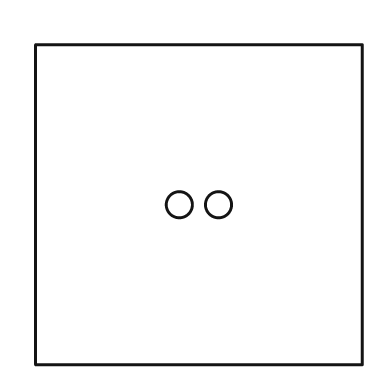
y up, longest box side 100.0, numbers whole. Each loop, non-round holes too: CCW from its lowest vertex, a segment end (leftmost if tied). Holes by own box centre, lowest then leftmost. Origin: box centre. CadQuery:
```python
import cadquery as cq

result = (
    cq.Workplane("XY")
    .moveTo(-50.0, -49.0)
    .lineTo(50.0, -49.0)
    .lineTo(50.0, 49.0)
    .lineTo(-50.0, 49.0)
    .close()
    .moveTo(-6.0, 0.0)
    .circle(4.0)
    .moveTo(6.0, 0.0)
    .circle(4.0)
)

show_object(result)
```